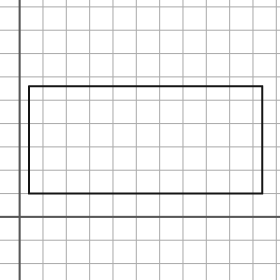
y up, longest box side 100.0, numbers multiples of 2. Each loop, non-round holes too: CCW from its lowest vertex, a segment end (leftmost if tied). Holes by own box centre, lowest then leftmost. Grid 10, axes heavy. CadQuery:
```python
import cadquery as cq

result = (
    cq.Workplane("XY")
    .moveTo(4.0, 10.0)
    .lineTo(104.0, 10.0)
    .lineTo(104.0, 56.0)
    .lineTo(4.0, 56.0)
    .close()
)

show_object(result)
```